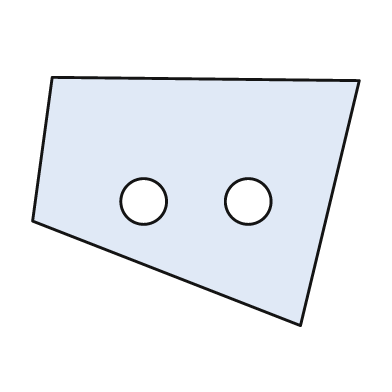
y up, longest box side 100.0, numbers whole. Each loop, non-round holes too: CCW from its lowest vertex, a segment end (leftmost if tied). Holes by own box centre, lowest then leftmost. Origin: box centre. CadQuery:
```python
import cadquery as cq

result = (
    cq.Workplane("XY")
    .moveTo(32.0, -38.0)
    .lineTo(50.0, 37.0)
    .lineTo(-44.0, 38.0)
    .lineTo(-50.0, -6.0)
    .close()
    .moveTo(-16.0, 0.0)
    .circle(7.0)
    .moveTo(16.0, 0.0)
    .circle(7.0)
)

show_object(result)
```